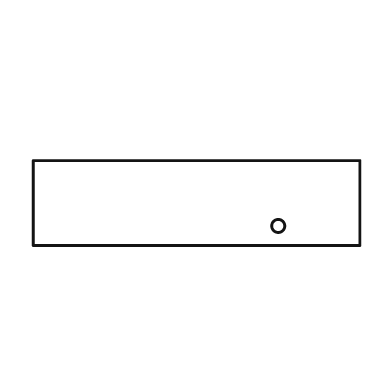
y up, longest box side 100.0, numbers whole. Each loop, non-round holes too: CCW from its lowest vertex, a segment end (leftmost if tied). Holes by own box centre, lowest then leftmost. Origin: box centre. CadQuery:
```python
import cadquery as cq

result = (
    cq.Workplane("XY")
    .moveTo(-50.0, -13.0)
    .lineTo(50.0, -13.0)
    .lineTo(50.0, 13.0)
    .lineTo(-50.0, 13.0)
    .close()
    .moveTo(25.0, -7.0)
    .circle(2.0)
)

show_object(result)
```